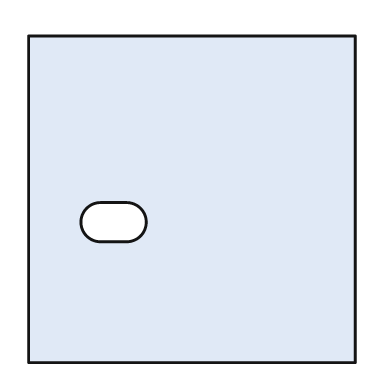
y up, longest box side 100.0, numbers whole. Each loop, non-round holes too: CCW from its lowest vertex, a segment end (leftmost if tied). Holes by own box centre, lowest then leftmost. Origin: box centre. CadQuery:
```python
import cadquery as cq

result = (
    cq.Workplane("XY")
    .moveTo(-50.0, -50.0)
    .lineTo(50.0, -50.0)
    .lineTo(50.0, 50.0)
    .lineTo(-50.0, 50.0)
    .close()
    .moveTo(-28.0, -13.0)
    .lineTo(-20.0, -13.0)
    .threePointArc((-14.0, -7.0), (-20.0, -1.0))
    .lineTo(-28.0, -1.0)
    .threePointArc((-34.0, -7.0), (-28.0, -13.0))
    .close()
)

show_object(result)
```